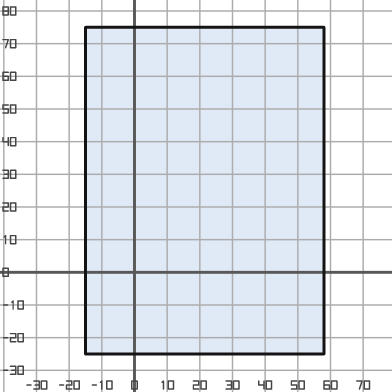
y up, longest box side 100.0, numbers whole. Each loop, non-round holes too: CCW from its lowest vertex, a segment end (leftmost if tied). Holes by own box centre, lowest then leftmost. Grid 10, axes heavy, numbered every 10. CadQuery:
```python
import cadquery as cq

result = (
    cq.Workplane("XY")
    .moveTo(-15.0, -25.0)
    .lineTo(58.0, -25.0)
    .lineTo(58.0, 75.0)
    .lineTo(-15.0, 75.0)
    .close()
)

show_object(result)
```